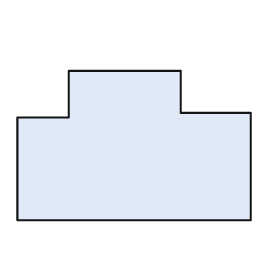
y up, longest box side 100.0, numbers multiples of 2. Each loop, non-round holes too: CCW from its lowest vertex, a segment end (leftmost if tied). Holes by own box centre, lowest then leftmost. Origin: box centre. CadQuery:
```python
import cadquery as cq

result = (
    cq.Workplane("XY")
    .moveTo(-50.0, -32.0)
    .lineTo(50.0, -32.0)
    .lineTo(50.0, 14.0)
    .lineTo(20.0, 14.0)
    .lineTo(20.0, 32.0)
    .lineTo(-28.0, 32.0)
    .lineTo(-28.0, 12.0)
    .lineTo(-50.0, 12.0)
    .close()
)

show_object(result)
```